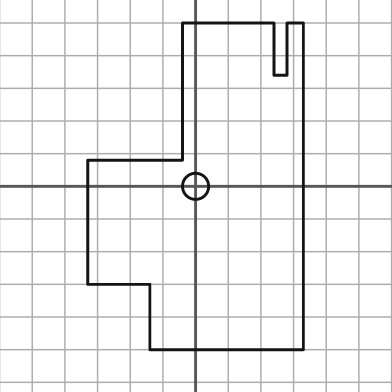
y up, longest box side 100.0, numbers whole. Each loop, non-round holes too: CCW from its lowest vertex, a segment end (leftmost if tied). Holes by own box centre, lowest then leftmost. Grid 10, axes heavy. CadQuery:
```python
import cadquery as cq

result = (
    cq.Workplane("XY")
    .moveTo(-14.0, -50.0)
    .lineTo(33.0, -50.0)
    .lineTo(33.0, 50.0)
    .lineTo(28.0, 50.0)
    .lineTo(28.0, 34.0)
    .lineTo(24.0, 34.0)
    .lineTo(24.0, 50.0)
    .lineTo(-4.0, 50.0)
    .lineTo(-4.0, 8.0)
    .lineTo(-33.0, 8.0)
    .lineTo(-33.0, -30.0)
    .lineTo(-14.0, -30.0)
    .close()
    .moveTo(0.0, 0.0)
    .circle(4.0)
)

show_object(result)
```